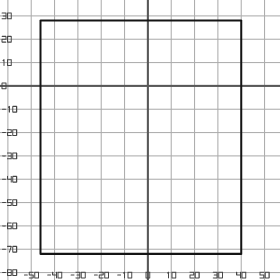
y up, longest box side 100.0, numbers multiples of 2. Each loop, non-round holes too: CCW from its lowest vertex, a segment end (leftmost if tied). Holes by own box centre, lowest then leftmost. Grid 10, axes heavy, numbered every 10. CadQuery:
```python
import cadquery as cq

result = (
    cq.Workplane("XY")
    .moveTo(-46.0, -72.0)
    .lineTo(40.0, -72.0)
    .lineTo(40.0, 28.0)
    .lineTo(-46.0, 28.0)
    .close()
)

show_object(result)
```